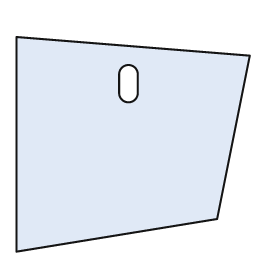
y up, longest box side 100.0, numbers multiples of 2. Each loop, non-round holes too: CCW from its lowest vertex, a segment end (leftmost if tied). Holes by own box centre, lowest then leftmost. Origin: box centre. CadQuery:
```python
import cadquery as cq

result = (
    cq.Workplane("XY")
    .moveTo(-50.0, -46.0)
    .lineTo(36.0, -32.0)
    .lineTo(50.0, 38.0)
    .lineTo(-50.0, 46.0)
    .close()
    .moveTo(-6.0, 22.0)
    .threePointArc((-2.0, 18.0), (2.0, 22.0))
    .lineTo(2.0, 30.0)
    .threePointArc((-2.0, 34.0), (-6.0, 30.0))
    .close()
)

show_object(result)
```